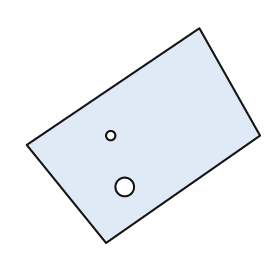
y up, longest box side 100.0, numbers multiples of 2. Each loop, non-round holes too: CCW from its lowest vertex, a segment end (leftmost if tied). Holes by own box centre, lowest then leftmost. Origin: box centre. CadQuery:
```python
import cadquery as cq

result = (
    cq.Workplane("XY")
    .moveTo(-16.0, -46.0)
    .lineTo(50.0, 0.0)
    .lineTo(24.0, 46.0)
    .lineTo(-50.0, -4.0)
    .close()
    .moveTo(-8.0, -22.0)
    .circle(4.0)
    .moveTo(-14.0, 0.0)
    .circle(2.0)
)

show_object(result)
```